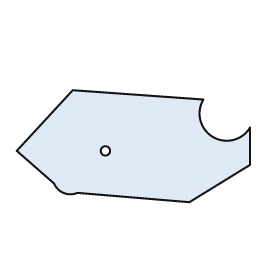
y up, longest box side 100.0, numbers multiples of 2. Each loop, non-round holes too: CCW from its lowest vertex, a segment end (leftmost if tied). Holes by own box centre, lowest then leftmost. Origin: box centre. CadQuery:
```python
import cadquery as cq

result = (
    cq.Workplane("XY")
    .moveTo(24.0, -24.0)
    .lineTo(50.0, -8.0)
    .lineTo(50.0, 8.0)
    .threePointArc((34.0, 4.0), (30.0, 20.0))
    .lineTo(-26.0, 24.0)
    .lineTo(-50.0, -2.0)
    .lineTo(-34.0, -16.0)
    .threePointArc((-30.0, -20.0), (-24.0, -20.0))
    .close()
    .moveTo(-12.0, -2.0)
    .circle(2.0)
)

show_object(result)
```